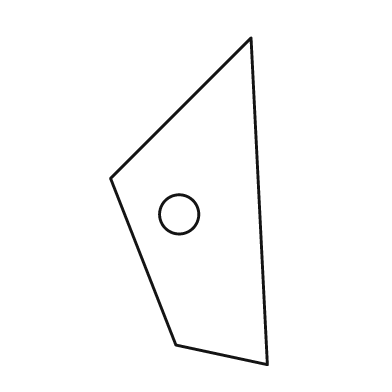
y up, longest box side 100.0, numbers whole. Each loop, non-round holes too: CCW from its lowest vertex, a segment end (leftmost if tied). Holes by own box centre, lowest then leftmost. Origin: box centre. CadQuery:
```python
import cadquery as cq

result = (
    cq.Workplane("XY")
    .moveTo(24.0, -50.0)
    .lineTo(19.0, 50.0)
    .lineTo(-24.0, 7.0)
    .lineTo(-4.0, -44.0)
    .close()
    .moveTo(-3.0, -4.0)
    .circle(6.0)
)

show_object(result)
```